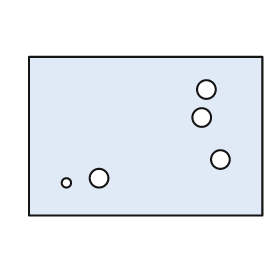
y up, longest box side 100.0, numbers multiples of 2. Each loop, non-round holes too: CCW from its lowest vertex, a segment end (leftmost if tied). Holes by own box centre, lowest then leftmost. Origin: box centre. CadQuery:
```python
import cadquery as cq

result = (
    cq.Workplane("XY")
    .moveTo(-50.0, -34.0)
    .lineTo(50.0, -34.0)
    .lineTo(50.0, 34.0)
    .lineTo(-50.0, 34.0)
    .close()
    .moveTo(-34.0, -20.0)
    .circle(2.0)
    .moveTo(-20.0, -18.0)
    .circle(4.0)
    .moveTo(32.0, -10.0)
    .circle(4.0)
    .moveTo(24.0, 8.0)
    .circle(4.0)
    .moveTo(26.0, 20.0)
    .circle(4.0)
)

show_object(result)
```